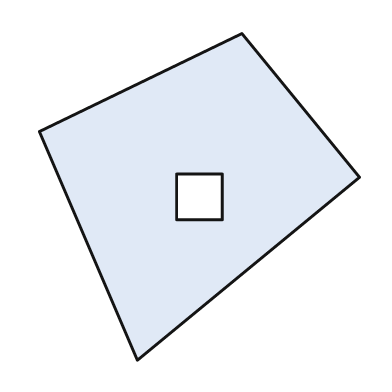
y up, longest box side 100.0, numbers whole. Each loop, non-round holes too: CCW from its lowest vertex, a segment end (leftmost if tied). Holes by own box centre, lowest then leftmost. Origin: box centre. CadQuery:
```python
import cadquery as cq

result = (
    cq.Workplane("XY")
    .moveTo(-19.0, -50.0)
    .lineTo(49.0, 6.0)
    .lineTo(13.0, 50.0)
    .lineTo(-49.0, 20.0)
    .close()
    .moveTo(-7.0, -7.0)
    .lineTo(7.0, -7.0)
    .lineTo(7.0, 7.0)
    .lineTo(-7.0, 7.0)
    .close()
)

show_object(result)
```